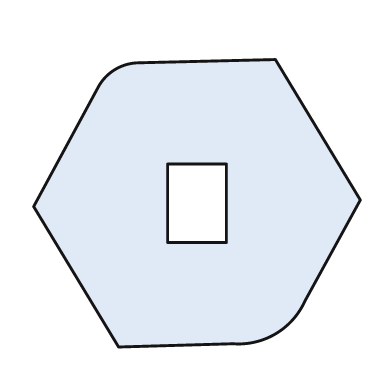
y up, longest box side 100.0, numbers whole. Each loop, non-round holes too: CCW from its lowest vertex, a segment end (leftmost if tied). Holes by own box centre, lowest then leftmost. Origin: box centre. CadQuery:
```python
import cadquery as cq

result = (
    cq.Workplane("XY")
    .moveTo(-24.0, -44.0)
    .lineTo(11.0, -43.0)
    .threePointArc((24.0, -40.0), (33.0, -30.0))
    .lineTo(50.0, 1.0)
    .lineTo(24.0, 44.0)
    .lineTo(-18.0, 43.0)
    .threePointArc((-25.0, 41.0), (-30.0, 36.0))
    .lineTo(-50.0, -1.0)
    .close()
    .moveTo(-9.0, -12.0)
    .lineTo(9.0, -12.0)
    .lineTo(9.0, 12.0)
    .lineTo(-9.0, 12.0)
    .close()
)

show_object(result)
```